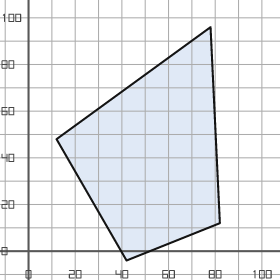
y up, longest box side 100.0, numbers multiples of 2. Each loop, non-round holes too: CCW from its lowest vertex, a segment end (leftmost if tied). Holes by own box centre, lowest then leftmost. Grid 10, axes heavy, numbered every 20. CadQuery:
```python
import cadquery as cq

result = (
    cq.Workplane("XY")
    .moveTo(42.0, -4.0)
    .lineTo(82.0, 12.0)
    .lineTo(78.0, 96.0)
    .lineTo(12.0, 48.0)
    .close()
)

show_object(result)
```